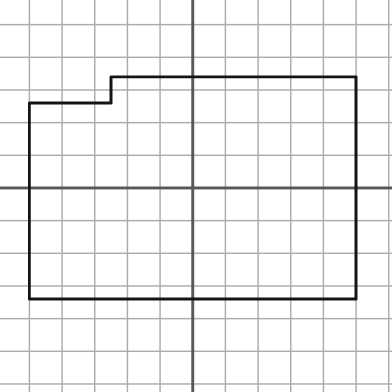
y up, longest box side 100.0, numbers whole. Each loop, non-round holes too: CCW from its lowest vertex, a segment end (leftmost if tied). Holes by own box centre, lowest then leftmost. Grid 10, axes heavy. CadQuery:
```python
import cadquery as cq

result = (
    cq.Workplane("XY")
    .moveTo(-50.0, -34.0)
    .lineTo(50.0, -34.0)
    .lineTo(50.0, 34.0)
    .lineTo(-25.0, 34.0)
    .lineTo(-25.0, 26.0)
    .lineTo(-50.0, 26.0)
    .close()
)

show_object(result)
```